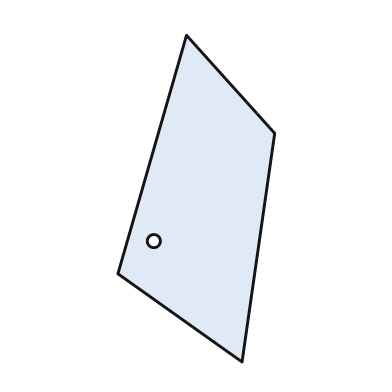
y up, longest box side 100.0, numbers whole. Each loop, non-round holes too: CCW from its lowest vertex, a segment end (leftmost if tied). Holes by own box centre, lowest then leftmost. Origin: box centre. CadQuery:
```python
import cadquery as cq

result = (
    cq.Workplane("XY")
    .moveTo(14.0, -50.0)
    .lineTo(24.0, 20.0)
    .lineTo(-3.0, 50.0)
    .lineTo(-24.0, -23.0)
    .close()
    .moveTo(-13.0, -13.0)
    .circle(2.0)
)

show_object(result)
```